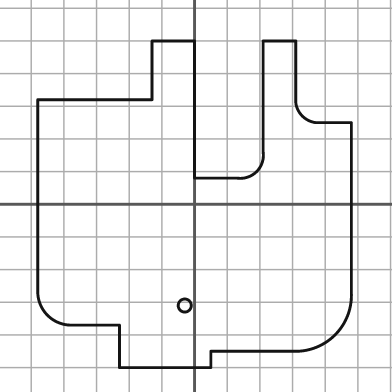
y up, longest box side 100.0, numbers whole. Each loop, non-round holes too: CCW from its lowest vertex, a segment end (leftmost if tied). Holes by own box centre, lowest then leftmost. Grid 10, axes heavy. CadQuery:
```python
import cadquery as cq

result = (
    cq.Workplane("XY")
    .moveTo(-23.0, -50.0)
    .lineTo(5.0, -50.0)
    .lineTo(5.0, -45.0)
    .lineTo(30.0, -45.0)
    .threePointArc((43.0, -40.0), (48.0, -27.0))
    .lineTo(48.0, 25.0)
    .lineTo(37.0, 25.0)
    .threePointArc((33.0, 27.0), (31.0, 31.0))
    .lineTo(31.0, 50.0)
    .lineTo(21.0, 50.0)
    .lineTo(21.0, 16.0)
    .threePointArc((19.0, 10.0), (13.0, 8.0))
    .lineTo(0.0, 8.0)
    .lineTo(0.0, 50.0)
    .lineTo(-13.0, 50.0)
    .lineTo(-13.0, 32.0)
    .lineTo(-48.0, 32.0)
    .lineTo(-48.0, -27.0)
    .threePointArc((-45.0, -34.0), (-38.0, -37.0))
    .lineTo(-23.0, -37.0)
    .close()
    .moveTo(-3.0, -31.0)
    .circle(2.0)
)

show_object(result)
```